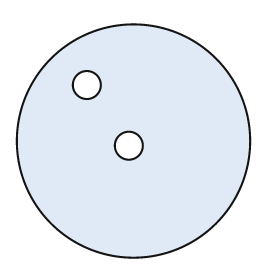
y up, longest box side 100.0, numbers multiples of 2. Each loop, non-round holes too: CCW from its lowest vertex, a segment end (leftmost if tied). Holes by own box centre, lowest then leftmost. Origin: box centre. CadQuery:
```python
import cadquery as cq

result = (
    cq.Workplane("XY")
    .moveTo(0.0, 0.0)
    .circle(50.0)
    .moveTo(-2.0, -2.0)
    .circle(6.0)
    .moveTo(-20.0, 24.0)
    .circle(6.0)
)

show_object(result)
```